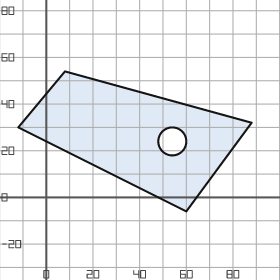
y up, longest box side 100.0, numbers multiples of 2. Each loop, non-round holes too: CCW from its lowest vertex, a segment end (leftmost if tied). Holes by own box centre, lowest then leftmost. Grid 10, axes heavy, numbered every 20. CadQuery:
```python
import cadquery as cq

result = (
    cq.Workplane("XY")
    .moveTo(60.0, -6.0)
    .lineTo(88.0, 32.0)
    .lineTo(8.0, 54.0)
    .lineTo(-12.0, 30.0)
    .close()
    .moveTo(54.0, 24.0)
    .circle(6.0)
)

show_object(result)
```